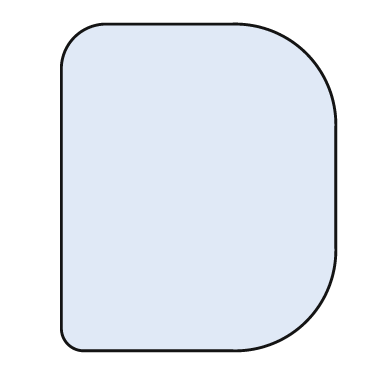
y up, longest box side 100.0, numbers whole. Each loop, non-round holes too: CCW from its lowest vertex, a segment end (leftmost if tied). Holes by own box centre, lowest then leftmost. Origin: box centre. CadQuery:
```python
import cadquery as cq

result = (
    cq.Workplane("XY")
    .moveTo(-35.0, -50.0)
    .lineTo(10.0, -50.0)
    .threePointArc((33.0, -41.0), (42.0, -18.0))
    .lineTo(42.0, 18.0)
    .threePointArc((33.0, 41.0), (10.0, 50.0))
    .lineTo(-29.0, 50.0)
    .threePointArc((-38.0, 46.0), (-42.0, 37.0))
    .lineTo(-42.0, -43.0)
    .threePointArc((-40.0, -48.0), (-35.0, -50.0))
    .close()
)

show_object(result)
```